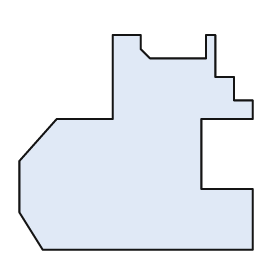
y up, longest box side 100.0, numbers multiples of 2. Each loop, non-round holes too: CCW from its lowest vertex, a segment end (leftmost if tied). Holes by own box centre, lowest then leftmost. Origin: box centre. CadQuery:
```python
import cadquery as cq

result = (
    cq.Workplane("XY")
    .moveTo(-40.0, -46.0)
    .lineTo(50.0, -46.0)
    .lineTo(50.0, -20.0)
    .lineTo(28.0, -20.0)
    .lineTo(28.0, 10.0)
    .lineTo(50.0, 10.0)
    .lineTo(50.0, 18.0)
    .lineTo(42.0, 18.0)
    .lineTo(42.0, 28.0)
    .lineTo(34.0, 28.0)
    .lineTo(34.0, 46.0)
    .lineTo(30.0, 46.0)
    .lineTo(30.0, 36.0)
    .lineTo(6.0, 36.0)
    .lineTo(2.0, 40.0)
    .lineTo(2.0, 46.0)
    .lineTo(-10.0, 46.0)
    .lineTo(-10.0, 10.0)
    .lineTo(-34.0, 10.0)
    .lineTo(-50.0, -8.0)
    .lineTo(-50.0, -30.0)
    .close()
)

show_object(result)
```